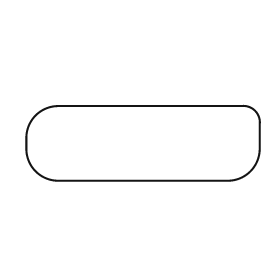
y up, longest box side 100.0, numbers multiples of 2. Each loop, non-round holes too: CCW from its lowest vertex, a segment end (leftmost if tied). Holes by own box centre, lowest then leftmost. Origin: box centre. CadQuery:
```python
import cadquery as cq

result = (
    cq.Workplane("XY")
    .moveTo(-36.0, -16.0)
    .lineTo(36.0, -16.0)
    .threePointArc((46.0, -12.0), (50.0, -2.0))
    .lineTo(50.0, 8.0)
    .threePointArc((48.0, 14.0), (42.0, 16.0))
    .lineTo(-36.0, 16.0)
    .threePointArc((-46.0, 12.0), (-50.0, 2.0))
    .lineTo(-50.0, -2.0)
    .threePointArc((-46.0, -12.0), (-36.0, -16.0))
    .close()
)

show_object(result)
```